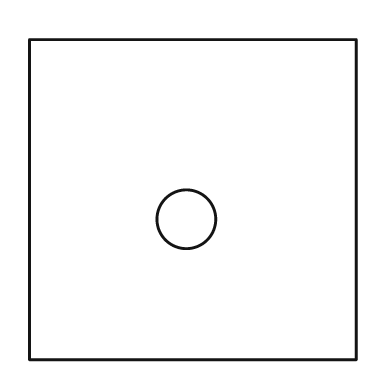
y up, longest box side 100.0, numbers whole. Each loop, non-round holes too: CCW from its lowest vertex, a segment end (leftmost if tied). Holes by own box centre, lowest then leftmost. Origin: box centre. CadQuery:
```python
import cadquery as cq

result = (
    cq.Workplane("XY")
    .moveTo(-50.0, -49.0)
    .lineTo(50.0, -49.0)
    .lineTo(50.0, 49.0)
    .lineTo(-50.0, 49.0)
    .close()
    .moveTo(-2.0, -6.0)
    .circle(9.0)
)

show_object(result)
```